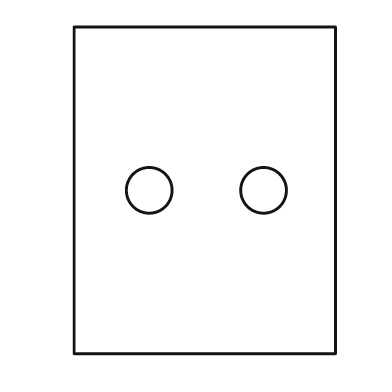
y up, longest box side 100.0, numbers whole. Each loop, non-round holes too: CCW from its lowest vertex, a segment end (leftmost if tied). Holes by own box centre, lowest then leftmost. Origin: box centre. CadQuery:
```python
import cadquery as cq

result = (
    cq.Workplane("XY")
    .moveTo(-40.0, -50.0)
    .lineTo(40.0, -50.0)
    .lineTo(40.0, 50.0)
    .lineTo(-40.0, 50.0)
    .close()
    .moveTo(-17.0, 0.0)
    .circle(7.0)
    .moveTo(18.0, 0.0)
    .circle(7.0)
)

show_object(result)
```